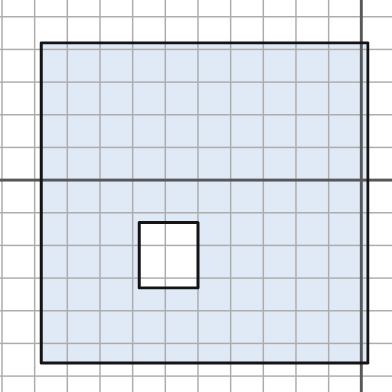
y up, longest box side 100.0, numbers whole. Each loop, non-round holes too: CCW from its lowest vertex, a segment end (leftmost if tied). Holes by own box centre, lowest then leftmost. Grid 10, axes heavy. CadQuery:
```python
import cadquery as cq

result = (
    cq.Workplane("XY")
    .moveTo(-98.0, -56.0)
    .lineTo(2.0, -56.0)
    .lineTo(2.0, 42.0)
    .lineTo(-98.0, 42.0)
    .close()
    .moveTo(-68.0, -33.0)
    .lineTo(-50.0, -33.0)
    .lineTo(-50.0, -13.0)
    .lineTo(-68.0, -13.0)
    .close()
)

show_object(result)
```